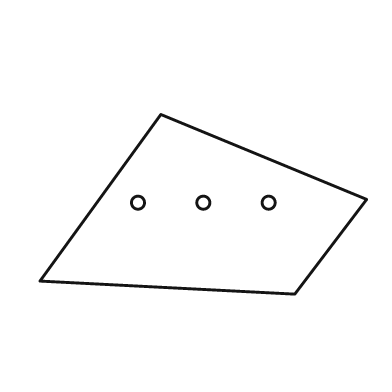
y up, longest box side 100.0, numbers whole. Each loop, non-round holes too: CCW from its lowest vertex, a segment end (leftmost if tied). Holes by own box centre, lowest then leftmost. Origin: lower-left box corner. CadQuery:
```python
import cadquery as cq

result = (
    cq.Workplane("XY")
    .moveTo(78.0, 0.0)
    .lineTo(100.0, 29.0)
    .lineTo(37.0, 55.0)
    .lineTo(0.0, 4.0)
    .close()
    .moveTo(30.0, 28.0)
    .circle(2.0)
    .moveTo(50.0, 28.0)
    .circle(2.0)
    .moveTo(70.0, 28.0)
    .circle(2.0)
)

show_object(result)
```